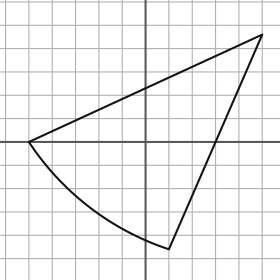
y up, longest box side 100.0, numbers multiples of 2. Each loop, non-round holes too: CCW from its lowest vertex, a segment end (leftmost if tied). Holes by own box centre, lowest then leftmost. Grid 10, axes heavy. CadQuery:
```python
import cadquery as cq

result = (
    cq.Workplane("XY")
    .moveTo(10.0, -46.0)
    .lineTo(50.0, 46.0)
    .lineTo(-50.0, 0.0)
    .threePointArc((-24.0, -28.0), (10.0, -46.0))
    .close()
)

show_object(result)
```